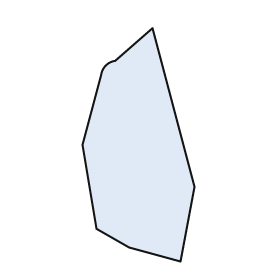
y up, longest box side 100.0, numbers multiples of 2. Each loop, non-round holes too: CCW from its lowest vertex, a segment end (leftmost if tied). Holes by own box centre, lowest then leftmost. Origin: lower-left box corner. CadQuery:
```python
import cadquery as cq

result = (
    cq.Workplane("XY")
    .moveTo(42.0, 0.0)
    .lineTo(48.0, 32.0)
    .lineTo(30.0, 100.0)
    .lineTo(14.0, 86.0)
    .threePointArc((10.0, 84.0), (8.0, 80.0))
    .lineTo(0.0, 50.0)
    .lineTo(6.0, 14.0)
    .lineTo(20.0, 6.0)
    .close()
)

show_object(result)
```